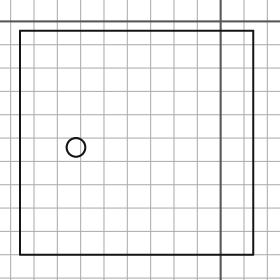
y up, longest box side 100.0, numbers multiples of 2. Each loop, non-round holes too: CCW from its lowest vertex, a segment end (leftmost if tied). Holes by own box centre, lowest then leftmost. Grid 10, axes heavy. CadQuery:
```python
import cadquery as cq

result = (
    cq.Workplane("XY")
    .moveTo(-86.0, -100.0)
    .lineTo(14.0, -100.0)
    .lineTo(14.0, -4.0)
    .lineTo(-86.0, -4.0)
    .close()
    .moveTo(-62.0, -54.0)
    .circle(4.0)
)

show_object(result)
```